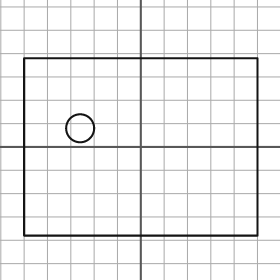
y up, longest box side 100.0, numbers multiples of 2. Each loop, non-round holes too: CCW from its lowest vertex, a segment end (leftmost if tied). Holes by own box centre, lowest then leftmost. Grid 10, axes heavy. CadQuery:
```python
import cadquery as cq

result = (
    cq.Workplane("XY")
    .moveTo(-50.0, -38.0)
    .lineTo(50.0, -38.0)
    .lineTo(50.0, 38.0)
    .lineTo(-50.0, 38.0)
    .close()
    .moveTo(-26.0, 8.0)
    .circle(6.0)
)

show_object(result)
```